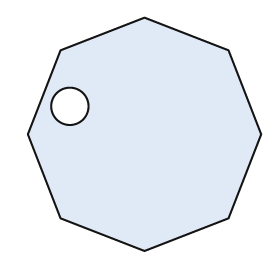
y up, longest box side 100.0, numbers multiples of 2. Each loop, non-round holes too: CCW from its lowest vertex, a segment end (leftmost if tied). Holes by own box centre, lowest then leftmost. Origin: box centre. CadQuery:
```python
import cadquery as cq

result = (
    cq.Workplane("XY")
    .moveTo(0.0, -50.0)
    .lineTo(36.0, -36.0)
    .lineTo(50.0, 0.0)
    .lineTo(36.0, 36.0)
    .lineTo(0.0, 50.0)
    .lineTo(-36.0, 36.0)
    .lineTo(-50.0, 0.0)
    .lineTo(-36.0, -36.0)
    .close()
    .moveTo(-32.0, 12.0)
    .circle(8.0)
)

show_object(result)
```